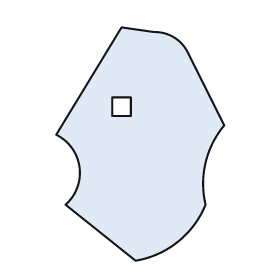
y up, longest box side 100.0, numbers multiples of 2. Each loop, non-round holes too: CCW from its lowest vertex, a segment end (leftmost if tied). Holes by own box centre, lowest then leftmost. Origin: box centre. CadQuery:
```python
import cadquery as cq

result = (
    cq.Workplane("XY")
    .moveTo(-2.0, -50.0)
    .threePointArc((16.0, -42.0), (28.0, -26.0))
    .threePointArc((28.0, -8.0), (36.0, 8.0))
    .lineTo(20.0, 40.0)
    .threePointArc((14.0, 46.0), (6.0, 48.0))
    .lineTo(-8.0, 50.0)
    .lineTo(-36.0, 4.0)
    .threePointArc((-26.0, -10.0), (-32.0, -26.0))
    .close()
    .moveTo(-12.0, 12.0)
    .lineTo(-4.0, 12.0)
    .lineTo(-4.0, 20.0)
    .lineTo(-12.0, 20.0)
    .close()
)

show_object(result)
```